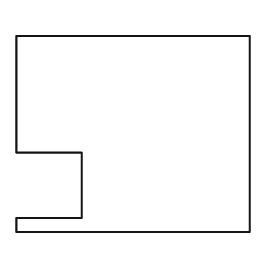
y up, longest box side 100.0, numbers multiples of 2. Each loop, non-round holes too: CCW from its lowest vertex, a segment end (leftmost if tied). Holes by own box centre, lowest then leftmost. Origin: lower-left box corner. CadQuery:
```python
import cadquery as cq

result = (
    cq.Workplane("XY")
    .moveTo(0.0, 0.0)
    .lineTo(100.0, 0.0)
    .lineTo(100.0, 84.0)
    .lineTo(0.0, 84.0)
    .lineTo(0.0, 34.0)
    .lineTo(28.0, 34.0)
    .lineTo(28.0, 6.0)
    .lineTo(0.0, 6.0)
    .close()
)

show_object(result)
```